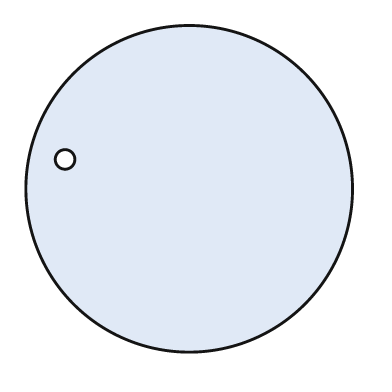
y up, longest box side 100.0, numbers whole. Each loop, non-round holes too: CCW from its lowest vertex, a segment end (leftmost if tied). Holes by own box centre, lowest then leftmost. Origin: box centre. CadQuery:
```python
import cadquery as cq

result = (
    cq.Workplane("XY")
    .moveTo(0.0, 0.0)
    .circle(50.0)
    .moveTo(-38.0, 9.0)
    .circle(3.0)
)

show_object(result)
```